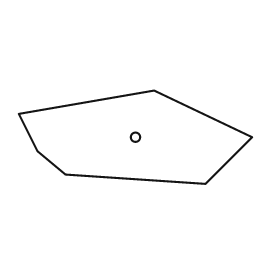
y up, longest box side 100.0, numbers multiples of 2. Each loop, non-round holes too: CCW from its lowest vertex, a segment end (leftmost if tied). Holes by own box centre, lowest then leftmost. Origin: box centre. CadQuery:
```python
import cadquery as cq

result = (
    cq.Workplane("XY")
    .moveTo(30.0, -20.0)
    .lineTo(50.0, 0.0)
    .lineTo(8.0, 20.0)
    .lineTo(-50.0, 10.0)
    .lineTo(-42.0, -6.0)
    .lineTo(-30.0, -16.0)
    .close()
    .moveTo(0.0, 0.0)
    .circle(2.0)
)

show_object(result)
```